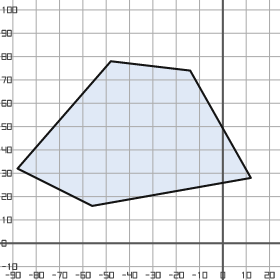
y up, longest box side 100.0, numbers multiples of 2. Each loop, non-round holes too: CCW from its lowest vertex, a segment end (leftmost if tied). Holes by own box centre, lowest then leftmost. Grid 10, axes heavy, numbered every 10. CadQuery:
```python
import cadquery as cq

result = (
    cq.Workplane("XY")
    .moveTo(-56.0, 16.0)
    .lineTo(12.0, 28.0)
    .lineTo(-14.0, 74.0)
    .lineTo(-48.0, 78.0)
    .lineTo(-88.0, 32.0)
    .close()
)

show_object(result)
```